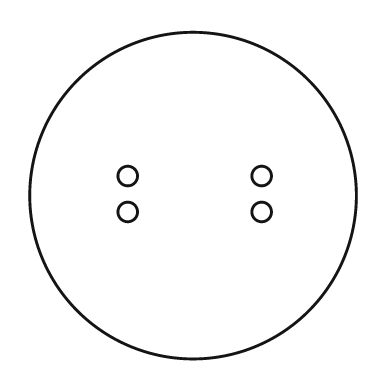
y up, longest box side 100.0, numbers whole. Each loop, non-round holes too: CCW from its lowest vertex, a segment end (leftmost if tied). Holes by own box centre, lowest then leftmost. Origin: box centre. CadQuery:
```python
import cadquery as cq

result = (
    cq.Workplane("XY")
    .moveTo(0.0, 0.0)
    .circle(50.0)
    .moveTo(-20.0, -5.0)
    .circle(3.0)
    .moveTo(21.0, -5.0)
    .circle(3.0)
    .moveTo(-20.0, 6.0)
    .circle(3.0)
    .moveTo(21.0, 6.0)
    .circle(3.0)
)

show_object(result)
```